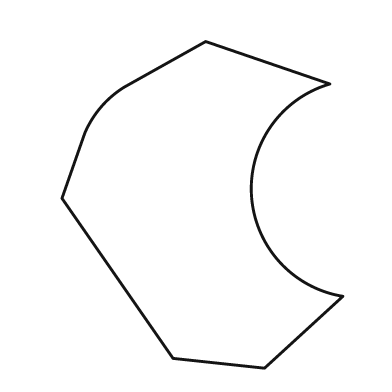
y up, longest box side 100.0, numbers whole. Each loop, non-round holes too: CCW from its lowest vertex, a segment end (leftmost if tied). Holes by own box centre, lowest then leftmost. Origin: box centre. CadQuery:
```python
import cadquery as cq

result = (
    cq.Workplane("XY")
    .moveTo(19.0, -50.0)
    .lineTo(43.0, -28.0)
    .threePointArc((15.0, 3.0), (39.0, 37.0))
    .lineTo(1.0, 50.0)
    .lineTo(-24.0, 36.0)
    .threePointArc((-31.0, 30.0), (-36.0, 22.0))
    .lineTo(-43.0, 2.0)
    .lineTo(-9.0, -47.0)
    .close()
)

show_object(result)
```